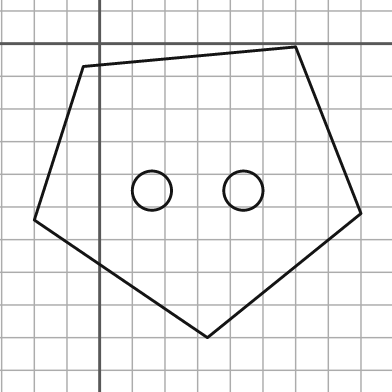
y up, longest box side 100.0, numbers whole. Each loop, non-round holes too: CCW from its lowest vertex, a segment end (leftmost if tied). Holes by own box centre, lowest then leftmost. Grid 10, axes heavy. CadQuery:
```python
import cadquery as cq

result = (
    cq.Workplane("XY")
    .moveTo(33.0, -90.0)
    .lineTo(80.0, -52.0)
    .lineTo(60.0, -1.0)
    .lineTo(-5.0, -7.0)
    .lineTo(-20.0, -54.0)
    .close()
    .moveTo(16.0, -45.0)
    .circle(6.0)
    .moveTo(44.0, -45.0)
    .circle(6.0)
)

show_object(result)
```